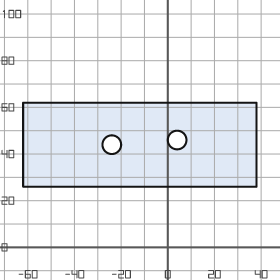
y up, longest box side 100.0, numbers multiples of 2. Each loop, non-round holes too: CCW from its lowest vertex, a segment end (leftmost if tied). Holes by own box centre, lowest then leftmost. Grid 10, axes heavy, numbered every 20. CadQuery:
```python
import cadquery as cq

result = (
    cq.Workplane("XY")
    .moveTo(-62.0, 26.0)
    .lineTo(38.0, 26.0)
    .lineTo(38.0, 62.0)
    .lineTo(-62.0, 62.0)
    .close()
    .moveTo(-24.0, 44.0)
    .circle(4.0)
    .moveTo(4.0, 46.0)
    .circle(4.0)
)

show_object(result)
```